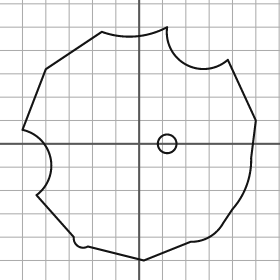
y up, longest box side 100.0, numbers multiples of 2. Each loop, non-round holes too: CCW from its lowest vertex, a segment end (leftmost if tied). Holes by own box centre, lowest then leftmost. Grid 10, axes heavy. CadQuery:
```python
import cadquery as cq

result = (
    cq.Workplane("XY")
    .moveTo(2.0, -50.0)
    .lineTo(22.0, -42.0)
    .threePointArc((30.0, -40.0), (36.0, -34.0))
    .lineTo(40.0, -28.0)
    .threePointArc((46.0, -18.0), (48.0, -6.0))
    .lineTo(50.0, 10.0)
    .lineTo(38.0, 36.0)
    .threePointArc((20.0, 34.0), (12.0, 50.0))
    .threePointArc((-2.0, 46.0), (-16.0, 48.0))
    .lineTo(-40.0, 32.0)
    .lineTo(-50.0, 6.0)
    .threePointArc((-38.0, -6.0), (-44.0, -22.0))
    .lineTo(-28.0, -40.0)
    .threePointArc((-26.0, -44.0), (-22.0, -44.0))
    .close()
    .moveTo(12.0, 0.0)
    .circle(4.0)
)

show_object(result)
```